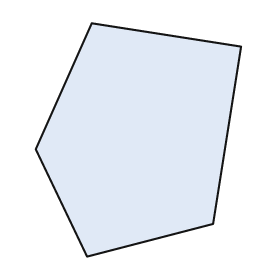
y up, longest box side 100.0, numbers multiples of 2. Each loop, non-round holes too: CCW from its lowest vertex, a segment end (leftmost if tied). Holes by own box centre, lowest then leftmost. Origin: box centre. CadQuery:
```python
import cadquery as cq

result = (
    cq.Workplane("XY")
    .moveTo(-22.0, -50.0)
    .lineTo(32.0, -36.0)
    .lineTo(44.0, 40.0)
    .lineTo(-20.0, 50.0)
    .lineTo(-44.0, -4.0)
    .close()
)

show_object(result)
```